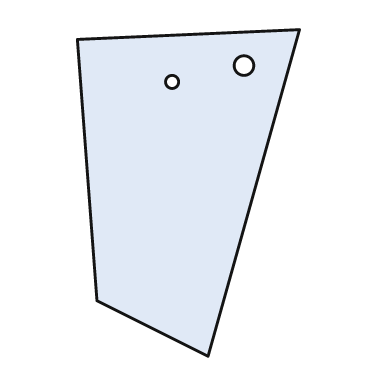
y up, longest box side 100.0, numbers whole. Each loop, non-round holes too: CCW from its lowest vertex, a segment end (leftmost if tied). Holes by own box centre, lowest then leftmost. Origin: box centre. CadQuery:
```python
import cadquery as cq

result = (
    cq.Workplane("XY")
    .moveTo(6.0, -50.0)
    .lineTo(34.0, 50.0)
    .lineTo(-34.0, 47.0)
    .lineTo(-28.0, -33.0)
    .close()
    .moveTo(-5.0, 34.0)
    .circle(2.0)
    .moveTo(17.0, 39.0)
    .circle(3.0)
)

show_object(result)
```